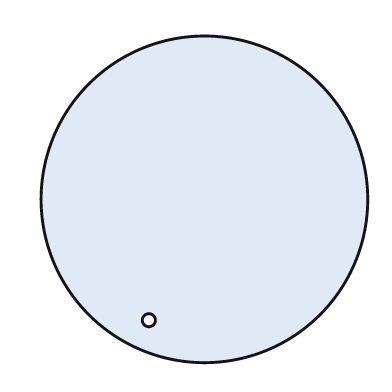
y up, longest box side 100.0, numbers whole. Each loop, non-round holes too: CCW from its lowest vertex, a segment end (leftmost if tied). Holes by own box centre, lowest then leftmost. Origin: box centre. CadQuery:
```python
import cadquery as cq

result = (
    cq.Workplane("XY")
    .moveTo(0.0, 0.0)
    .circle(50.0)
    .moveTo(-17.0, -37.0)
    .circle(2.0)
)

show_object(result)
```